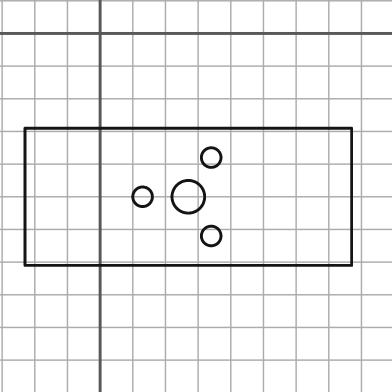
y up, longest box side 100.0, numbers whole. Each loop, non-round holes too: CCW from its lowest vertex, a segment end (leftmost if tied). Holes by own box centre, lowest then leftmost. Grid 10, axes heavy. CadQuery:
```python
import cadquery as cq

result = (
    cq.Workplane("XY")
    .moveTo(-23.0, -71.0)
    .lineTo(77.0, -71.0)
    .lineTo(77.0, -29.0)
    .lineTo(-23.0, -29.0)
    .close()
    .moveTo(34.0, -62.0)
    .circle(3.0)
    .moveTo(13.0, -50.0)
    .circle(3.0)
    .moveTo(27.0, -50.0)
    .circle(5.0)
    .moveTo(34.0, -38.0)
    .circle(3.0)
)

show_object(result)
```